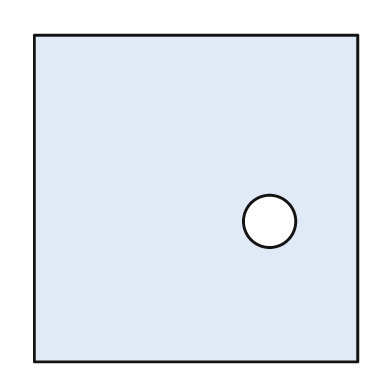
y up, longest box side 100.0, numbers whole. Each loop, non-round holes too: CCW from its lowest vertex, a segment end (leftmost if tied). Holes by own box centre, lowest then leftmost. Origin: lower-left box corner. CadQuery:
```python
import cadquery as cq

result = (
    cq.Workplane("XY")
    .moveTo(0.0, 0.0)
    .lineTo(99.0, 0.0)
    .lineTo(99.0, 100.0)
    .lineTo(0.0, 100.0)
    .close()
    .moveTo(72.0, 43.0)
    .circle(8.0)
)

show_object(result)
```